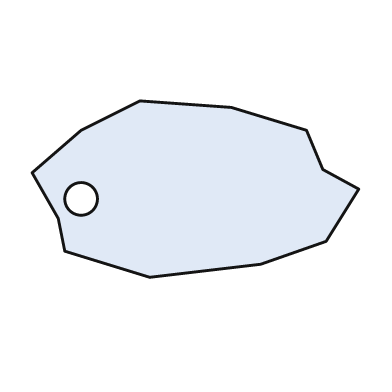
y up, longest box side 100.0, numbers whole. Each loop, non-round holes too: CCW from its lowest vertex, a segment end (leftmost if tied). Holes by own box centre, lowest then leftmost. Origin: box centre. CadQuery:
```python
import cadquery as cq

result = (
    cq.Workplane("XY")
    .moveTo(-14.0, -27.0)
    .lineTo(20.0, -23.0)
    .lineTo(40.0, -16.0)
    .lineTo(50.0, 0.0)
    .lineTo(39.0, 6.0)
    .lineTo(34.0, 18.0)
    .lineTo(11.0, 25.0)
    .lineTo(-17.0, 27.0)
    .lineTo(-35.0, 18.0)
    .lineTo(-50.0, 5.0)
    .lineTo(-42.0, -9.0)
    .lineTo(-40.0, -19.0)
    .close()
    .moveTo(-35.0, -3.0)
    .circle(5.0)
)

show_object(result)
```